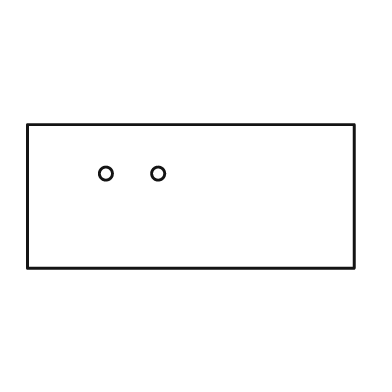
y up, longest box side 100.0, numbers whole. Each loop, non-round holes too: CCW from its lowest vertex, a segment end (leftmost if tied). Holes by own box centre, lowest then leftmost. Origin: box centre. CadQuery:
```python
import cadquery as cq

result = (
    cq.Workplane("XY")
    .moveTo(-50.0, -22.0)
    .lineTo(50.0, -22.0)
    .lineTo(50.0, 22.0)
    .lineTo(-50.0, 22.0)
    .close()
    .moveTo(-26.0, 7.0)
    .circle(2.0)
    .moveTo(-10.0, 7.0)
    .circle(2.0)
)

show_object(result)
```